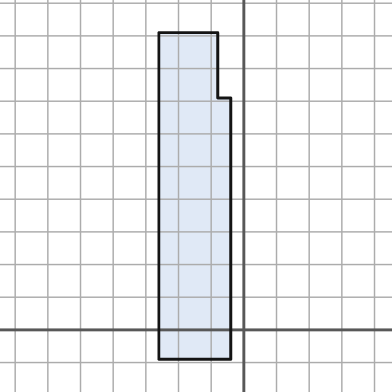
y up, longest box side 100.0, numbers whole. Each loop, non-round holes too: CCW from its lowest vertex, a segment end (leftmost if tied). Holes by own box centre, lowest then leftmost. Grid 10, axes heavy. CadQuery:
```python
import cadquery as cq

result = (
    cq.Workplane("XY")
    .moveTo(-26.0, -9.0)
    .lineTo(-4.0, -9.0)
    .lineTo(-4.0, 71.0)
    .lineTo(-8.0, 71.0)
    .lineTo(-8.0, 91.0)
    .lineTo(-26.0, 91.0)
    .close()
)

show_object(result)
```